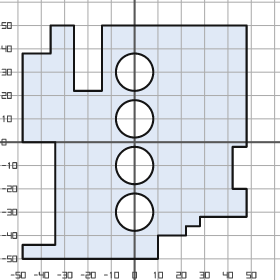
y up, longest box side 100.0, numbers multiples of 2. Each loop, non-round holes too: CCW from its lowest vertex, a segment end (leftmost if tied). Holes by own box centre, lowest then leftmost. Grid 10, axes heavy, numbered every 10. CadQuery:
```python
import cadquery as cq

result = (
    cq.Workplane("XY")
    .moveTo(-48.0, -50.0)
    .lineTo(10.0, -50.0)
    .lineTo(10.0, -40.0)
    .lineTo(22.0, -40.0)
    .lineTo(22.0, -36.0)
    .lineTo(28.0, -36.0)
    .lineTo(28.0, -32.0)
    .lineTo(48.0, -32.0)
    .lineTo(48.0, -20.0)
    .lineTo(42.0, -20.0)
    .lineTo(42.0, -2.0)
    .lineTo(48.0, -2.0)
    .lineTo(48.0, 50.0)
    .lineTo(-14.0, 50.0)
    .lineTo(-14.0, 22.0)
    .lineTo(-26.0, 22.0)
    .lineTo(-26.0, 50.0)
    .lineTo(-36.0, 50.0)
    .lineTo(-36.0, 38.0)
    .lineTo(-48.0, 38.0)
    .lineTo(-48.0, 0.0)
    .lineTo(-34.0, 0.0)
    .lineTo(-34.0, -44.0)
    .lineTo(-48.0, -44.0)
    .close()
    .moveTo(0.0, -30.0)
    .circle(8.0)
    .moveTo(0.0, -10.0)
    .circle(8.0)
    .moveTo(0.0, 10.0)
    .circle(8.0)
    .moveTo(0.0, 30.0)
    .circle(8.0)
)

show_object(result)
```